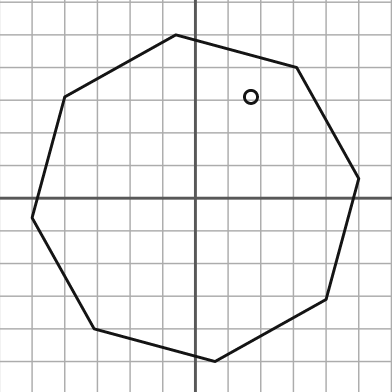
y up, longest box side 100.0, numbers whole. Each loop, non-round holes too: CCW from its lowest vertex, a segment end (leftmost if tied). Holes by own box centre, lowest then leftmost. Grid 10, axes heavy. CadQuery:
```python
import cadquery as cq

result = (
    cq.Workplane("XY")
    .moveTo(6.0, -50.0)
    .lineTo(40.0, -31.0)
    .lineTo(50.0, 6.0)
    .lineTo(31.0, 40.0)
    .lineTo(-6.0, 50.0)
    .lineTo(-40.0, 31.0)
    .lineTo(-50.0, -6.0)
    .lineTo(-31.0, -40.0)
    .close()
    .moveTo(17.0, 31.0)
    .circle(2.0)
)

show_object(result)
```